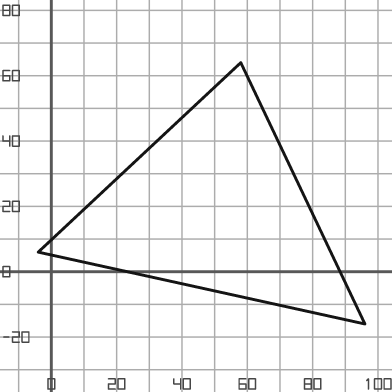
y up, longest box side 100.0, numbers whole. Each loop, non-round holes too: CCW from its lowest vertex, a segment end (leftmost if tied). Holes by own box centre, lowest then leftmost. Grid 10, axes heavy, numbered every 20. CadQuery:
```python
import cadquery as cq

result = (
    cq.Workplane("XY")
    .moveTo(96.0, -16.0)
    .lineTo(58.0, 64.0)
    .lineTo(-4.0, 6.0)
    .close()
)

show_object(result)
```